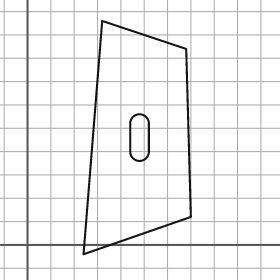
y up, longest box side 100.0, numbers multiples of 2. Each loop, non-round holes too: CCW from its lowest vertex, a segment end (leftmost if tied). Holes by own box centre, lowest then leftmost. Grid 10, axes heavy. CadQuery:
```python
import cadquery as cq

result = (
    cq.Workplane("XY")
    .moveTo(24.0, -4.0)
    .lineTo(70.0, 12.0)
    .lineTo(68.0, 84.0)
    .lineTo(32.0, 96.0)
    .close()
    .moveTo(44.0, 40.0)
    .threePointArc((48.0, 36.0), (52.0, 40.0))
    .lineTo(52.0, 52.0)
    .threePointArc((48.0, 56.0), (44.0, 52.0))
    .close()
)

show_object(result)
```